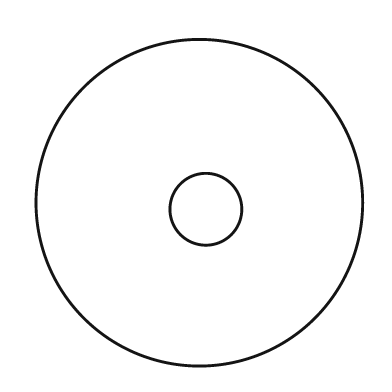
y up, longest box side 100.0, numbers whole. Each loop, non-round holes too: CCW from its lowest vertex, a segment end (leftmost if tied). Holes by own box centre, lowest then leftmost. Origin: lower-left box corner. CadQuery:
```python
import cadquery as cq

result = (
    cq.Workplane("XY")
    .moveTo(50.0, 50.0)
    .circle(50.0)
    .moveTo(52.0, 48.0)
    .circle(11.0)
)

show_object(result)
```